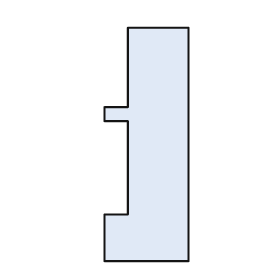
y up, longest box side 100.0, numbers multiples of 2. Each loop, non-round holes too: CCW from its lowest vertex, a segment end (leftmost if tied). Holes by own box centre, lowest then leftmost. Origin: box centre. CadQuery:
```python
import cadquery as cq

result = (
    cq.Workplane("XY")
    .moveTo(-18.0, -50.0)
    .lineTo(18.0, -50.0)
    .lineTo(18.0, 50.0)
    .lineTo(-8.0, 50.0)
    .lineTo(-8.0, 16.0)
    .lineTo(-18.0, 16.0)
    .lineTo(-18.0, 10.0)
    .lineTo(-8.0, 10.0)
    .lineTo(-8.0, -30.0)
    .lineTo(-18.0, -30.0)
    .close()
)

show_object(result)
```